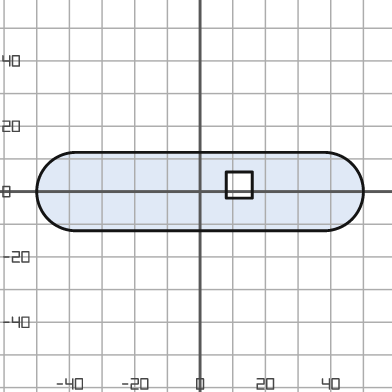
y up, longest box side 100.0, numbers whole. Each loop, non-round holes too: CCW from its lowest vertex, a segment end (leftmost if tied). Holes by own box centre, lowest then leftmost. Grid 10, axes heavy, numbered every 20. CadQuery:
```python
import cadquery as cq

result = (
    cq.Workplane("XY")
    .moveTo(-38.0, -12.0)
    .lineTo(38.0, -12.0)
    .threePointArc((50.0, 0.0), (38.0, 12.0))
    .lineTo(-38.0, 12.0)
    .threePointArc((-50.0, 0.0), (-38.0, -12.0))
    .close()
    .moveTo(8.0, -2.0)
    .lineTo(16.0, -2.0)
    .lineTo(16.0, 6.0)
    .lineTo(8.0, 6.0)
    .close()
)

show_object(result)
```